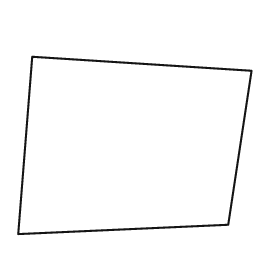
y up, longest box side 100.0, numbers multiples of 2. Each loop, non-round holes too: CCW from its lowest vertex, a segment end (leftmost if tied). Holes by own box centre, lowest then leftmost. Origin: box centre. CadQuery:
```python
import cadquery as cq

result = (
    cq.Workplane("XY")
    .moveTo(-50.0, -38.0)
    .lineTo(40.0, -34.0)
    .lineTo(50.0, 32.0)
    .lineTo(-44.0, 38.0)
    .close()
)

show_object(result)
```